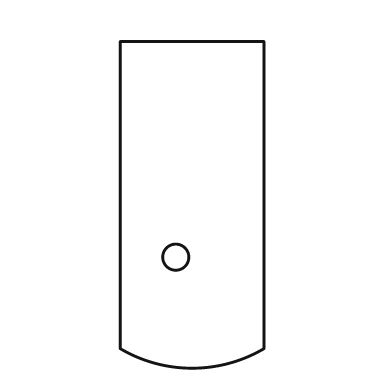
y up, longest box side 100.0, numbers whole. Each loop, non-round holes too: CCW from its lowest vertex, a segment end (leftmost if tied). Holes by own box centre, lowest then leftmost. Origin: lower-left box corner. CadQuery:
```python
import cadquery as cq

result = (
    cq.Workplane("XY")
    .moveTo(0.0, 6.0)
    .threePointArc((22.0, 0.0), (44.0, 6.0))
    .lineTo(44.0, 100.0)
    .lineTo(0.0, 100.0)
    .close()
    .moveTo(17.0, 34.0)
    .circle(4.0)
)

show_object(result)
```